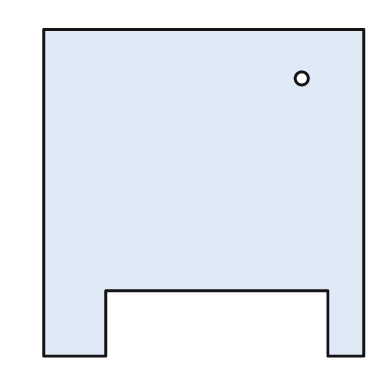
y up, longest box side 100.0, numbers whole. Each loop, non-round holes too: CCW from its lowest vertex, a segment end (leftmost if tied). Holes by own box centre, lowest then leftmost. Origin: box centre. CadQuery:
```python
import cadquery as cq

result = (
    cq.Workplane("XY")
    .moveTo(-49.0, -50.0)
    .lineTo(-30.0, -50.0)
    .lineTo(-30.0, -30.0)
    .lineTo(38.0, -30.0)
    .lineTo(38.0, -50.0)
    .lineTo(49.0, -50.0)
    .lineTo(49.0, 50.0)
    .lineTo(-49.0, 50.0)
    .close()
    .moveTo(30.0, 35.0)
    .circle(2.0)
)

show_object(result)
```